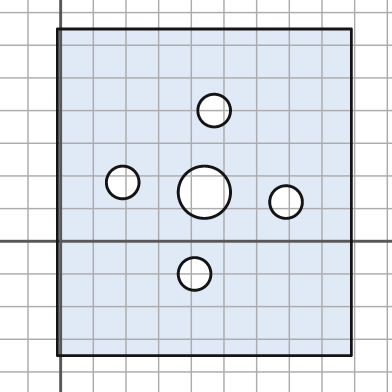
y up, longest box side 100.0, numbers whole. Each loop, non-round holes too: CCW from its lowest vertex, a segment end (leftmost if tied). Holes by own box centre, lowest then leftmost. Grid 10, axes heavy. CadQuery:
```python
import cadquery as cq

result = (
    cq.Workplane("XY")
    .moveTo(-1.0, -35.0)
    .lineTo(89.0, -35.0)
    .lineTo(89.0, 65.0)
    .lineTo(-1.0, 65.0)
    .close()
    .moveTo(41.0, -10.0)
    .circle(5.0)
    .moveTo(69.0, 12.0)
    .circle(5.0)
    .moveTo(44.0, 15.0)
    .circle(8.0)
    .moveTo(19.0, 18.0)
    .circle(5.0)
    .moveTo(47.0, 40.0)
    .circle(5.0)
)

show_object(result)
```